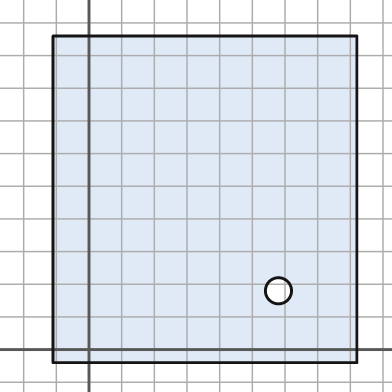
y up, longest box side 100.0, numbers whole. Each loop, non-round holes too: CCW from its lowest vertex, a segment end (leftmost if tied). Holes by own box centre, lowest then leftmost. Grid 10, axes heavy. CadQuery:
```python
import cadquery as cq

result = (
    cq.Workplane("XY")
    .moveTo(-11.0, -4.0)
    .lineTo(82.0, -4.0)
    .lineTo(82.0, 96.0)
    .lineTo(-11.0, 96.0)
    .close()
    .moveTo(58.0, 18.0)
    .circle(4.0)
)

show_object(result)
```